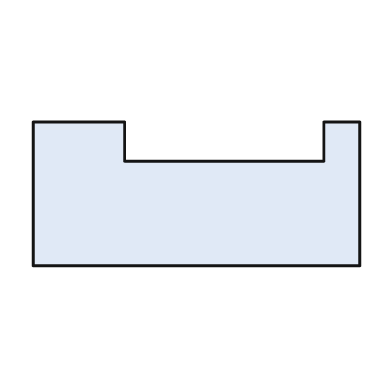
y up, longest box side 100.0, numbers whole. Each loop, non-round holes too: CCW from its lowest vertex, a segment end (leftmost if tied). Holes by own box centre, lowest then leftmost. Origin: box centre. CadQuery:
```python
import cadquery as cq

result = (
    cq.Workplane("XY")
    .moveTo(-50.0, -22.0)
    .lineTo(50.0, -22.0)
    .lineTo(50.0, 22.0)
    .lineTo(39.0, 22.0)
    .lineTo(39.0, 10.0)
    .lineTo(-22.0, 10.0)
    .lineTo(-22.0, 22.0)
    .lineTo(-50.0, 22.0)
    .close()
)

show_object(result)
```